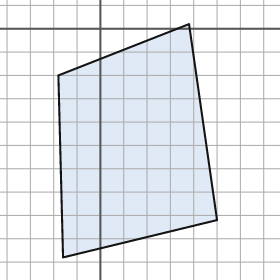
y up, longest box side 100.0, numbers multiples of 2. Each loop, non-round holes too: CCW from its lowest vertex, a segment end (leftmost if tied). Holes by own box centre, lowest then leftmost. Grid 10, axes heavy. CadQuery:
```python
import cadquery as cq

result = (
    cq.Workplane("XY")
    .moveTo(-16.0, -98.0)
    .lineTo(50.0, -82.0)
    .lineTo(38.0, 2.0)
    .lineTo(-18.0, -20.0)
    .close()
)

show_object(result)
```